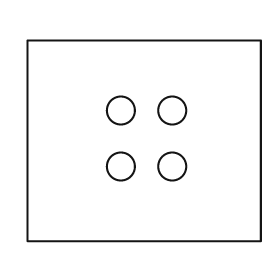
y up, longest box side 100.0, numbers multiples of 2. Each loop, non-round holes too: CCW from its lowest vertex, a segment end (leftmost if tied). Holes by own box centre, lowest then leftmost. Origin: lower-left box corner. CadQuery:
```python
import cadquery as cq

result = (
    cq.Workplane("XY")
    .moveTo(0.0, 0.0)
    .lineTo(100.0, 0.0)
    .lineTo(100.0, 86.0)
    .lineTo(0.0, 86.0)
    .close()
    .moveTo(40.0, 32.0)
    .circle(6.0)
    .moveTo(62.0, 32.0)
    .circle(6.0)
    .moveTo(40.0, 56.0)
    .circle(6.0)
    .moveTo(62.0, 56.0)
    .circle(6.0)
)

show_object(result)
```